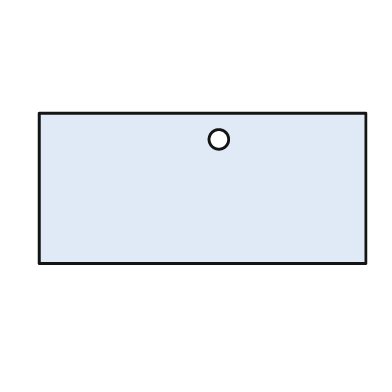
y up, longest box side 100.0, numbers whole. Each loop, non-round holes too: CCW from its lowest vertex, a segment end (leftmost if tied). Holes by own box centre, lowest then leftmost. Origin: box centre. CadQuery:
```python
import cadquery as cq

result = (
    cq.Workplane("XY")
    .moveTo(-50.0, -23.0)
    .lineTo(50.0, -23.0)
    .lineTo(50.0, 23.0)
    .lineTo(-50.0, 23.0)
    .close()
    .moveTo(5.0, 15.0)
    .circle(3.0)
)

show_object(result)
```